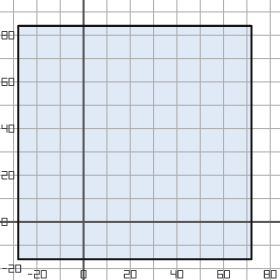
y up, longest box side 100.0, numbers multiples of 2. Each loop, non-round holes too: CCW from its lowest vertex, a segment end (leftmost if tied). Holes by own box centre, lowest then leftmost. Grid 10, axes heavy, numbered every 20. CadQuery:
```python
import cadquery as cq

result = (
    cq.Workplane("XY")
    .moveTo(-28.0, -16.0)
    .lineTo(72.0, -16.0)
    .lineTo(72.0, 84.0)
    .lineTo(-28.0, 84.0)
    .close()
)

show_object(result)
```